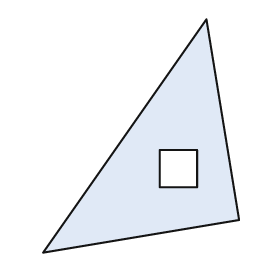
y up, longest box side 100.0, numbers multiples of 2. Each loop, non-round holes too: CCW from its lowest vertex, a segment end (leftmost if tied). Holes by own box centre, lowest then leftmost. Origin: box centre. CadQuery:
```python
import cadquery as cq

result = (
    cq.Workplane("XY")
    .moveTo(-42.0, -50.0)
    .lineTo(42.0, -36.0)
    .lineTo(28.0, 50.0)
    .close()
    .moveTo(8.0, -22.0)
    .lineTo(24.0, -22.0)
    .lineTo(24.0, -6.0)
    .lineTo(8.0, -6.0)
    .close()
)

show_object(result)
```